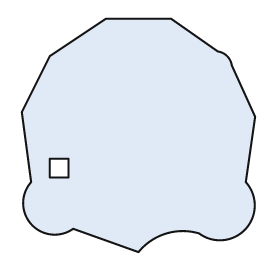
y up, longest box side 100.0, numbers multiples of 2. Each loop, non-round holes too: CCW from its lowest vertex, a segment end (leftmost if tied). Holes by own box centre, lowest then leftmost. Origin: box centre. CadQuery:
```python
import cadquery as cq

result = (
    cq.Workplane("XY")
    .moveTo(0.0, -50.0)
    .threePointArc((12.0, -42.0), (26.0, -42.0))
    .threePointArc((46.0, -40.0), (46.0, -20.0))
    .lineTo(50.0, 8.0)
    .lineTo(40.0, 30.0)
    .threePointArc((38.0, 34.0), (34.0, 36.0))
    .lineTo(14.0, 50.0)
    .lineTo(-14.0, 50.0)
    .lineTo(-38.0, 34.0)
    .lineTo(-50.0, 10.0)
    .lineTo(-46.0, -20.0)
    .threePointArc((-46.0, -38.0), (-28.0, -40.0))
    .close()
    .moveTo(-38.0, -18.0)
    .lineTo(-30.0, -18.0)
    .lineTo(-30.0, -10.0)
    .lineTo(-38.0, -10.0)
    .close()
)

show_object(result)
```